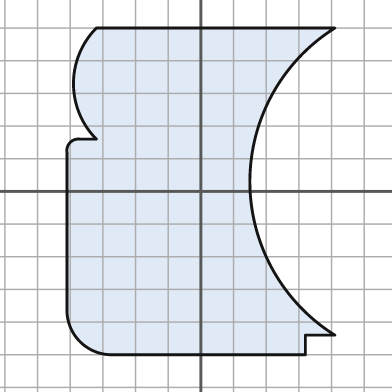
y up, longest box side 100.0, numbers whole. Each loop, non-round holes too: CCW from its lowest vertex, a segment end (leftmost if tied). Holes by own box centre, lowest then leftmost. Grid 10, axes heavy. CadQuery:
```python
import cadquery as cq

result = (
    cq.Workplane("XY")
    .moveTo(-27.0, -50.0)
    .lineTo(32.0, -50.0)
    .lineTo(32.0, -44.0)
    .lineTo(41.0, -44.0)
    .threePointArc((15.0, 3.0), (41.0, 50.0))
    .lineTo(-32.0, 50.0)
    .threePointArc((-39.0, 33.0), (-32.0, 16.0))
    .lineTo(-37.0, 16.0)
    .threePointArc((-40.0, 15.0), (-41.0, 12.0))
    .lineTo(-41.0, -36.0)
    .threePointArc((-37.0, -46.0), (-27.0, -50.0))
    .close()
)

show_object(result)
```